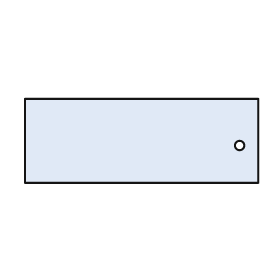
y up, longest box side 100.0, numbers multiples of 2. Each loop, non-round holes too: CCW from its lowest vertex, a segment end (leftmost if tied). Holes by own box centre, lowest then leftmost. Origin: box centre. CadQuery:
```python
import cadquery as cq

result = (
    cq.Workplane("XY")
    .moveTo(-50.0, -18.0)
    .lineTo(50.0, -18.0)
    .lineTo(50.0, 18.0)
    .lineTo(-50.0, 18.0)
    .close()
    .moveTo(42.0, -2.0)
    .circle(2.0)
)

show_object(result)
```